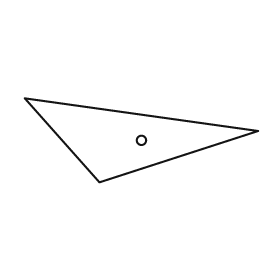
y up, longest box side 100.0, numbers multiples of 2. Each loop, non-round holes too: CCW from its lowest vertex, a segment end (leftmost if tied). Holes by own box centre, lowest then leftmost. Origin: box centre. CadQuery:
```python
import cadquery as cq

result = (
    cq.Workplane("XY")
    .moveTo(-18.0, -18.0)
    .lineTo(50.0, 4.0)
    .lineTo(-50.0, 18.0)
    .close()
    .moveTo(0.0, 0.0)
    .circle(2.0)
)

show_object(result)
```